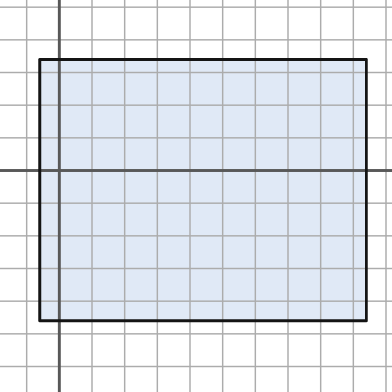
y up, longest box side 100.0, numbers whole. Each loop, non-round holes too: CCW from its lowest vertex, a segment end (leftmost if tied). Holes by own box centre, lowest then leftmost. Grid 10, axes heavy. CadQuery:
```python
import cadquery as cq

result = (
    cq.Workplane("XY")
    .moveTo(-6.0, -46.0)
    .lineTo(94.0, -46.0)
    .lineTo(94.0, 34.0)
    .lineTo(-6.0, 34.0)
    .close()
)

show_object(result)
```